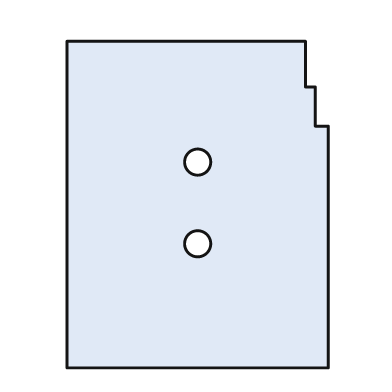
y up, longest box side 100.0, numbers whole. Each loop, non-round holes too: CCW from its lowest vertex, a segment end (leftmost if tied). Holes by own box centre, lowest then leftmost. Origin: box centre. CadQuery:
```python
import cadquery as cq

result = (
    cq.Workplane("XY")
    .moveTo(-40.0, -50.0)
    .lineTo(40.0, -50.0)
    .lineTo(40.0, 24.0)
    .lineTo(36.0, 24.0)
    .lineTo(36.0, 36.0)
    .lineTo(33.0, 36.0)
    .lineTo(33.0, 50.0)
    .lineTo(-40.0, 50.0)
    .close()
    .moveTo(0.0, -12.0)
    .circle(4.0)
    .moveTo(0.0, 13.0)
    .circle(4.0)
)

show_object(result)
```